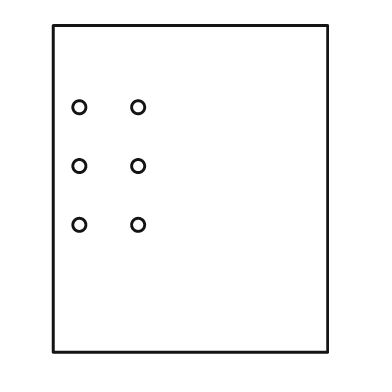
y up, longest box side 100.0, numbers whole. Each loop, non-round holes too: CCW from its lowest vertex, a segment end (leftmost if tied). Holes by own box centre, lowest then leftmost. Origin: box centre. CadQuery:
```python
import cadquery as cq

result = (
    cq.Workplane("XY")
    .moveTo(-42.0, -50.0)
    .lineTo(42.0, -50.0)
    .lineTo(42.0, 50.0)
    .lineTo(-42.0, 50.0)
    .close()
    .moveTo(-34.0, -11.0)
    .circle(2.0)
    .moveTo(-16.0, -11.0)
    .circle(2.0)
    .moveTo(-34.0, 7.0)
    .circle(2.0)
    .moveTo(-16.0, 7.0)
    .circle(2.0)
    .moveTo(-34.0, 25.0)
    .circle(2.0)
    .moveTo(-16.0, 25.0)
    .circle(2.0)
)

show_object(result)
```